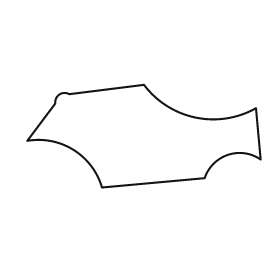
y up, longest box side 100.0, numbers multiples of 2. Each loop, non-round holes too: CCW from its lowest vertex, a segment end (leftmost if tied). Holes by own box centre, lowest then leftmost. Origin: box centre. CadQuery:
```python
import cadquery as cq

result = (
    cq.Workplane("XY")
    .moveTo(-18.0, -22.0)
    .lineTo(26.0, -18.0)
    .threePointArc((36.0, -8.0), (50.0, -10.0))
    .lineTo(48.0, 12.0)
    .threePointArc((22.0, 8.0), (0.0, 22.0))
    .lineTo(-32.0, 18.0)
    .threePointArc((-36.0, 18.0), (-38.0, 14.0))
    .lineTo(-50.0, -2.0)
    .threePointArc((-30.0, -6.0), (-18.0, -22.0))
    .close()
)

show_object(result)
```